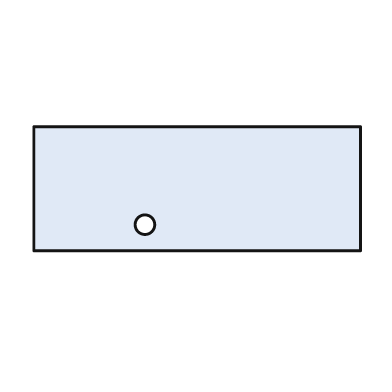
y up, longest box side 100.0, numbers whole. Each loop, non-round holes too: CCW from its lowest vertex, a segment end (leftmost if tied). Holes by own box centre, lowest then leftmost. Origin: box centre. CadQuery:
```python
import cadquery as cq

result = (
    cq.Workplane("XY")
    .moveTo(-50.0, -19.0)
    .lineTo(50.0, -19.0)
    .lineTo(50.0, 19.0)
    .lineTo(-50.0, 19.0)
    .close()
    .moveTo(-16.0, -11.0)
    .circle(3.0)
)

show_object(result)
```